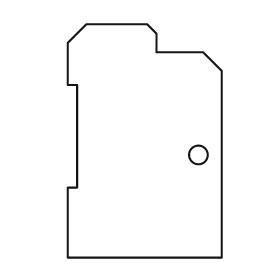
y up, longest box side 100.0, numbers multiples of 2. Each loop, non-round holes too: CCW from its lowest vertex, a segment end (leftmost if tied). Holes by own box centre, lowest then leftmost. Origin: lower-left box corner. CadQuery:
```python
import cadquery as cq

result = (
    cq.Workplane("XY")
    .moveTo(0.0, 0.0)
    .lineTo(66.0, 0.0)
    .lineTo(66.0, 80.0)
    .lineTo(58.0, 88.0)
    .lineTo(38.0, 88.0)
    .lineTo(38.0, 96.0)
    .lineTo(34.0, 100.0)
    .lineTo(8.0, 100.0)
    .lineTo(0.0, 92.0)
    .lineTo(0.0, 74.0)
    .lineTo(4.0, 74.0)
    .lineTo(4.0, 30.0)
    .lineTo(0.0, 30.0)
    .close()
    .moveTo(56.0, 44.0)
    .circle(4.0)
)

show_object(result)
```